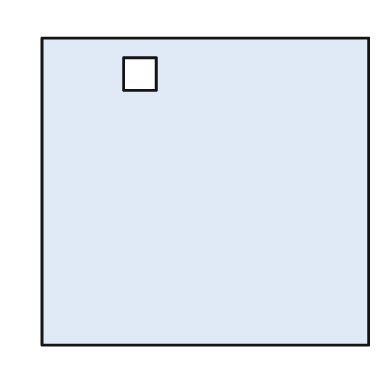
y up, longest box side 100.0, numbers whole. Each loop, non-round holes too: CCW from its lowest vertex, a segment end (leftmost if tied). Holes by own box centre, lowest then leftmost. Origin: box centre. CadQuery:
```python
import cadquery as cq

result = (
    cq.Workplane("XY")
    .moveTo(-50.0, -47.0)
    .lineTo(50.0, -47.0)
    .lineTo(50.0, 47.0)
    .lineTo(-50.0, 47.0)
    .close()
    .moveTo(-25.0, 31.0)
    .lineTo(-15.0, 31.0)
    .lineTo(-15.0, 41.0)
    .lineTo(-25.0, 41.0)
    .close()
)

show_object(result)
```